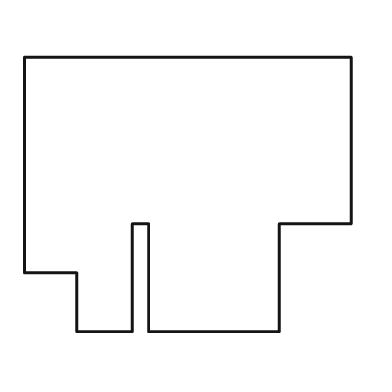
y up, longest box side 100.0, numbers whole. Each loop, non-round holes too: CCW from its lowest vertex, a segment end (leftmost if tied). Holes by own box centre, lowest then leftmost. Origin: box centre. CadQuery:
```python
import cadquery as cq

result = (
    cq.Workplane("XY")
    .moveTo(-34.0, -42.0)
    .lineTo(-17.0, -42.0)
    .lineTo(-17.0, -9.0)
    .lineTo(-12.0, -9.0)
    .lineTo(-12.0, -42.0)
    .lineTo(28.0, -42.0)
    .lineTo(28.0, -9.0)
    .lineTo(50.0, -9.0)
    .lineTo(50.0, 42.0)
    .lineTo(-50.0, 42.0)
    .lineTo(-50.0, -24.0)
    .lineTo(-34.0, -24.0)
    .close()
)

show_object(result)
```